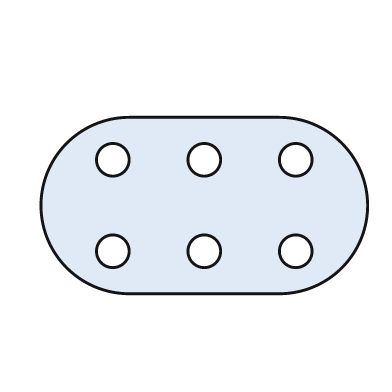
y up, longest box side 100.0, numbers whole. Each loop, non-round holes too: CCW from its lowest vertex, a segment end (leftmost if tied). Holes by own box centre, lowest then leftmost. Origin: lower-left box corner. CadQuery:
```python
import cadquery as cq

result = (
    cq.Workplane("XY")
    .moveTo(27.0, 0.0)
    .lineTo(73.0, 0.0)
    .threePointArc((100.0, 27.0), (73.0, 54.0))
    .lineTo(27.0, 54.0)
    .threePointArc((0.0, 27.0), (27.0, 0.0))
    .close()
    .moveTo(22.0, 13.0)
    .circle(5.0)
    .moveTo(50.0, 13.0)
    .circle(5.0)
    .moveTo(78.0, 13.0)
    .circle(5.0)
    .moveTo(22.0, 41.0)
    .circle(5.0)
    .moveTo(50.0, 41.0)
    .circle(5.0)
    .moveTo(78.0, 41.0)
    .circle(5.0)
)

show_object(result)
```